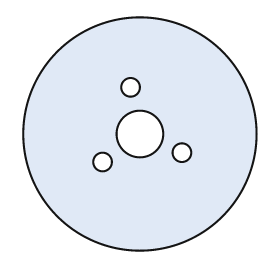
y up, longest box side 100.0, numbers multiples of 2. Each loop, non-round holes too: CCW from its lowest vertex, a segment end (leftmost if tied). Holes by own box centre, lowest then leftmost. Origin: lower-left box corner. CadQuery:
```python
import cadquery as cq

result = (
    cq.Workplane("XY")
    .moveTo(50.0, 50.0)
    .circle(50.0)
    .moveTo(34.0, 38.0)
    .circle(4.0)
    .moveTo(68.0, 42.0)
    .circle(4.0)
    .moveTo(50.0, 50.0)
    .circle(10.0)
    .moveTo(46.0, 70.0)
    .circle(4.0)
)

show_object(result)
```